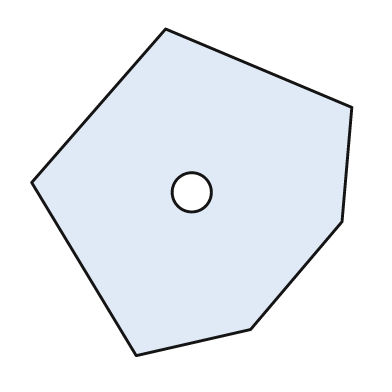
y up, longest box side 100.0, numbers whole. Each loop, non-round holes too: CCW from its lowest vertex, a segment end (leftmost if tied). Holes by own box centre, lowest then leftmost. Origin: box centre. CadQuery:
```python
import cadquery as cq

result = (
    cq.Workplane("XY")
    .moveTo(-17.0, -50.0)
    .lineTo(18.0, -42.0)
    .lineTo(46.0, -9.0)
    .lineTo(49.0, 26.0)
    .lineTo(-8.0, 50.0)
    .lineTo(-49.0, 3.0)
    .close()
    .moveTo(0.0, 0.0)
    .circle(6.0)
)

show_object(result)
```